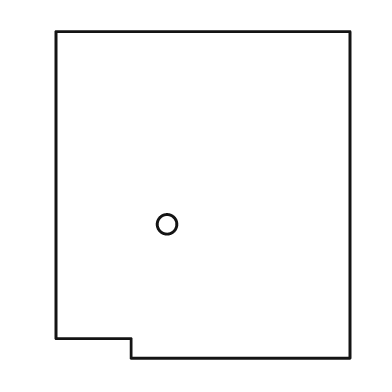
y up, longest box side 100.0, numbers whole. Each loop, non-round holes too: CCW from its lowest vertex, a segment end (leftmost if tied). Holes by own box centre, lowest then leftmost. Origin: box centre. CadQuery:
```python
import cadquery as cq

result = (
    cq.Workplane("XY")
    .moveTo(-22.0, -50.0)
    .lineTo(45.0, -50.0)
    .lineTo(45.0, 50.0)
    .lineTo(-45.0, 50.0)
    .lineTo(-45.0, -44.0)
    .lineTo(-22.0, -44.0)
    .close()
    .moveTo(-11.0, -9.0)
    .circle(3.0)
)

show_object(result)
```